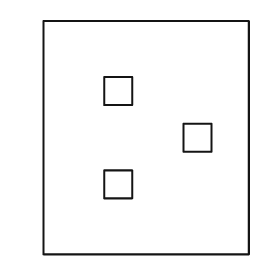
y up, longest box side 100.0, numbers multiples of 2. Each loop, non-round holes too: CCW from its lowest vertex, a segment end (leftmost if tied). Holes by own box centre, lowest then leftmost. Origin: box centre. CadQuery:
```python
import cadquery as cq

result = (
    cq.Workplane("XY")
    .moveTo(-44.0, -50.0)
    .lineTo(44.0, -50.0)
    .lineTo(44.0, 50.0)
    .lineTo(-44.0, 50.0)
    .close()
    .moveTo(-18.0, -26.0)
    .lineTo(-6.0, -26.0)
    .lineTo(-6.0, -14.0)
    .lineTo(-18.0, -14.0)
    .close()
    .moveTo(16.0, -6.0)
    .lineTo(28.0, -6.0)
    .lineTo(28.0, 6.0)
    .lineTo(16.0, 6.0)
    .close()
    .moveTo(-18.0, 14.0)
    .lineTo(-6.0, 14.0)
    .lineTo(-6.0, 26.0)
    .lineTo(-18.0, 26.0)
    .close()
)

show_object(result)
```